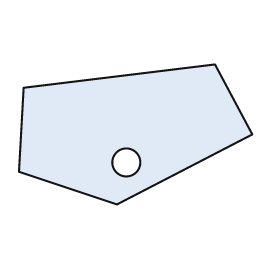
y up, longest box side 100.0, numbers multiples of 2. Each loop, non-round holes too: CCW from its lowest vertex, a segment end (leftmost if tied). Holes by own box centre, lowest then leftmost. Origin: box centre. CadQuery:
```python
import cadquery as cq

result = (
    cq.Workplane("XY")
    .moveTo(-8.0, -30.0)
    .lineTo(50.0, 0.0)
    .lineTo(34.0, 30.0)
    .lineTo(-48.0, 20.0)
    .lineTo(-50.0, -16.0)
    .close()
    .moveTo(-4.0, -12.0)
    .circle(6.0)
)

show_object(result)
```